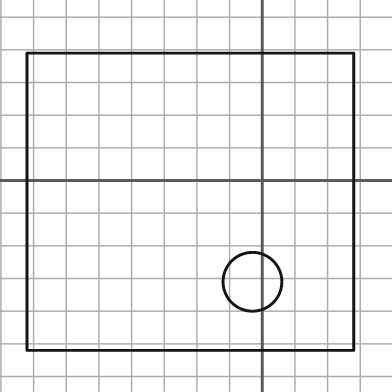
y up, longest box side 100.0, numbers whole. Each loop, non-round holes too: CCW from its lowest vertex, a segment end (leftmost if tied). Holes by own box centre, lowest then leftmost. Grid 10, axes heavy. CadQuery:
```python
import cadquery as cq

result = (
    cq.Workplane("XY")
    .moveTo(-72.0, -52.0)
    .lineTo(28.0, -52.0)
    .lineTo(28.0, 39.0)
    .lineTo(-72.0, 39.0)
    .close()
    .moveTo(-3.0, -31.0)
    .circle(9.0)
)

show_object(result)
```